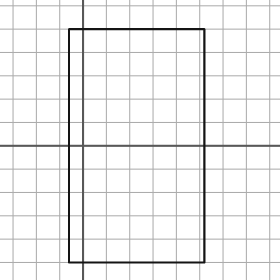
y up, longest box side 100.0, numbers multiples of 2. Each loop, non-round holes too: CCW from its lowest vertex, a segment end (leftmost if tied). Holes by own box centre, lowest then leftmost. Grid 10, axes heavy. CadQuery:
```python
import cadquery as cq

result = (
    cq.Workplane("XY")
    .moveTo(-6.0, -50.0)
    .lineTo(52.0, -50.0)
    .lineTo(52.0, 50.0)
    .lineTo(-6.0, 50.0)
    .close()
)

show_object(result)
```